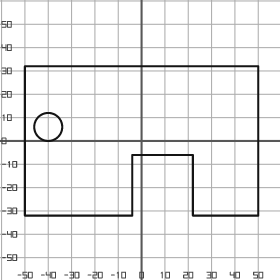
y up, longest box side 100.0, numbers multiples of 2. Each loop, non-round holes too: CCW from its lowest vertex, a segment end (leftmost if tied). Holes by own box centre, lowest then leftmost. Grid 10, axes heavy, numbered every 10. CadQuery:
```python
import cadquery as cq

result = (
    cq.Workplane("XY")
    .moveTo(-50.0, -32.0)
    .lineTo(-4.0, -32.0)
    .lineTo(-4.0, -6.0)
    .lineTo(22.0, -6.0)
    .lineTo(22.0, -32.0)
    .lineTo(50.0, -32.0)
    .lineTo(50.0, 32.0)
    .lineTo(-50.0, 32.0)
    .close()
    .moveTo(-40.0, 6.0)
    .circle(6.0)
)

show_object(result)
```